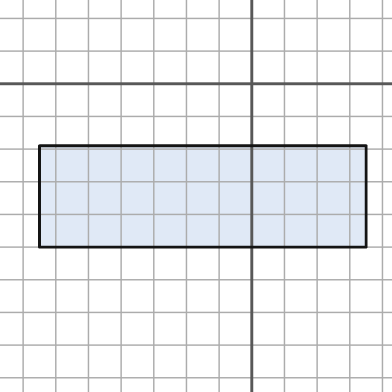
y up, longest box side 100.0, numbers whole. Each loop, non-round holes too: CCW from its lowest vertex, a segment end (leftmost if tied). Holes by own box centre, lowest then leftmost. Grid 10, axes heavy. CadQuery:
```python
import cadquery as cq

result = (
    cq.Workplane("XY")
    .moveTo(-65.0, -50.0)
    .lineTo(35.0, -50.0)
    .lineTo(35.0, -19.0)
    .lineTo(-65.0, -19.0)
    .close()
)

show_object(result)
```